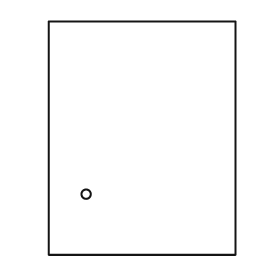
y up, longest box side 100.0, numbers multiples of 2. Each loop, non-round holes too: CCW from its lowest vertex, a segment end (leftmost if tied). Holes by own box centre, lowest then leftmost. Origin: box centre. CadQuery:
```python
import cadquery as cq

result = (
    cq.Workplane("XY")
    .moveTo(-40.0, -50.0)
    .lineTo(40.0, -50.0)
    .lineTo(40.0, 50.0)
    .lineTo(-40.0, 50.0)
    .close()
    .moveTo(-24.0, -24.0)
    .circle(2.0)
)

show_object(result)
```